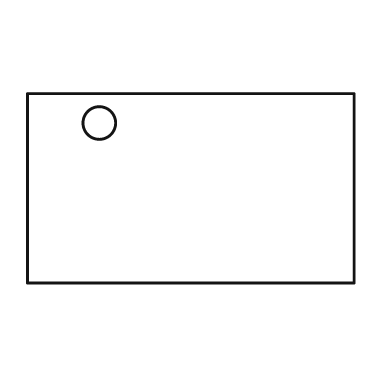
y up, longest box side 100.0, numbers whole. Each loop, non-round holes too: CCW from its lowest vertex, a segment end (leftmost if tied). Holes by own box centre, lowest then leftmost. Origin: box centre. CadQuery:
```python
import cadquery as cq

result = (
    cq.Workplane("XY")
    .moveTo(-50.0, -29.0)
    .lineTo(50.0, -29.0)
    .lineTo(50.0, 29.0)
    .lineTo(-50.0, 29.0)
    .close()
    .moveTo(-28.0, 20.0)
    .circle(5.0)
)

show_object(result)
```